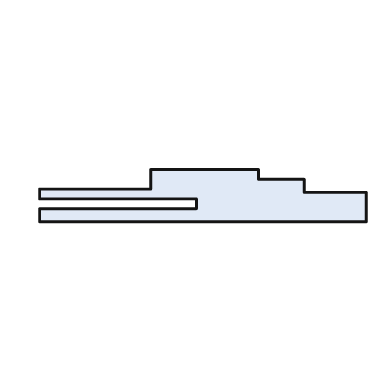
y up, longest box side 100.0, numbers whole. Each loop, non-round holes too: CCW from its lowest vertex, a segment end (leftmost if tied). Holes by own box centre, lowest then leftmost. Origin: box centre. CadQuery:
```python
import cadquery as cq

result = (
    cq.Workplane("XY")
    .moveTo(-50.0, -8.0)
    .lineTo(50.0, -8.0)
    .lineTo(50.0, 1.0)
    .lineTo(31.0, 1.0)
    .lineTo(31.0, 5.0)
    .lineTo(17.0, 5.0)
    .lineTo(17.0, 8.0)
    .lineTo(-16.0, 8.0)
    .lineTo(-16.0, 2.0)
    .lineTo(-50.0, 2.0)
    .lineTo(-50.0, -1.0)
    .lineTo(-2.0, -1.0)
    .lineTo(-2.0, -4.0)
    .lineTo(-50.0, -4.0)
    .close()
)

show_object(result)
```